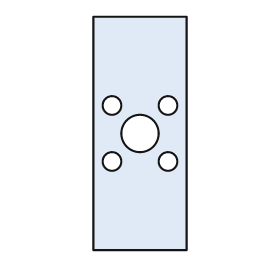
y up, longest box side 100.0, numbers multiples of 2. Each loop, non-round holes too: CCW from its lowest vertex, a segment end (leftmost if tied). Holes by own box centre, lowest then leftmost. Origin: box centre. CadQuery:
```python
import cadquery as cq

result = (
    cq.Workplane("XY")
    .moveTo(-20.0, -50.0)
    .lineTo(20.0, -50.0)
    .lineTo(20.0, 50.0)
    .lineTo(-20.0, 50.0)
    .close()
    .moveTo(-12.0, -12.0)
    .circle(4.0)
    .moveTo(12.0, -12.0)
    .circle(4.0)
    .moveTo(0.0, 0.0)
    .circle(8.0)
    .moveTo(-12.0, 12.0)
    .circle(4.0)
    .moveTo(12.0, 12.0)
    .circle(4.0)
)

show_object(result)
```